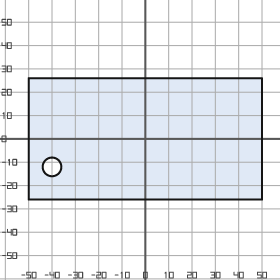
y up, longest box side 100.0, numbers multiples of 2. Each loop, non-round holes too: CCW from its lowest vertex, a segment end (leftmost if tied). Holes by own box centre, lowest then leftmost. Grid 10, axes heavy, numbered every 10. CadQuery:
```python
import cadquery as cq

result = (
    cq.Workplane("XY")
    .moveTo(-50.0, -26.0)
    .lineTo(50.0, -26.0)
    .lineTo(50.0, 26.0)
    .lineTo(-50.0, 26.0)
    .close()
    .moveTo(-40.0, -12.0)
    .circle(4.0)
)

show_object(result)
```